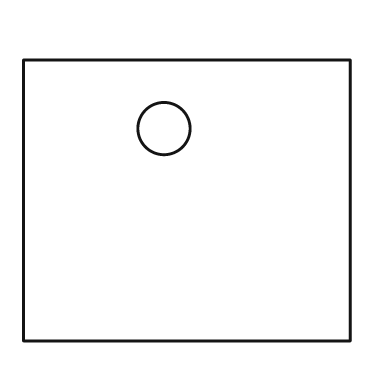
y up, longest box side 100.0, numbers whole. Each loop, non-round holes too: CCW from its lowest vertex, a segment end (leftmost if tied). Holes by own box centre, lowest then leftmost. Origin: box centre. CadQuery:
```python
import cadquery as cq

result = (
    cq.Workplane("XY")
    .moveTo(-50.0, -43.0)
    .lineTo(50.0, -43.0)
    .lineTo(50.0, 43.0)
    .lineTo(-50.0, 43.0)
    .close()
    .moveTo(-7.0, 22.0)
    .circle(8.0)
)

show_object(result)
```